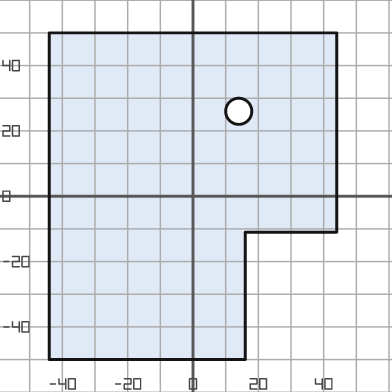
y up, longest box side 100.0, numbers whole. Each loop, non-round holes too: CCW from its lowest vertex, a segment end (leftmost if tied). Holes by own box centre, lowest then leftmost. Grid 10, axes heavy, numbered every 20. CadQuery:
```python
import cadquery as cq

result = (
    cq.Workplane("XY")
    .moveTo(-44.0, -50.0)
    .lineTo(16.0, -50.0)
    .lineTo(16.0, -11.0)
    .lineTo(44.0, -11.0)
    .lineTo(44.0, 50.0)
    .lineTo(-44.0, 50.0)
    .close()
    .moveTo(14.0, 26.0)
    .circle(4.0)
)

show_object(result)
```